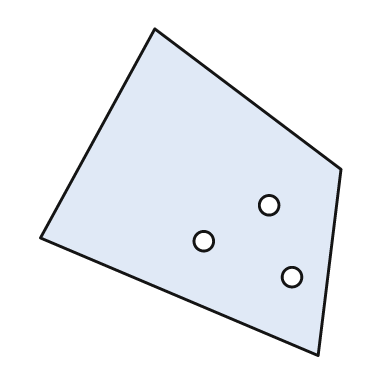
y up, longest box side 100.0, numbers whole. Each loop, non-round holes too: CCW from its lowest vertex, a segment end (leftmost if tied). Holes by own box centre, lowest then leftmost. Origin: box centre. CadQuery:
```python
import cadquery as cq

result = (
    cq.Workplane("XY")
    .moveTo(39.0, -50.0)
    .lineTo(46.0, 7.0)
    .lineTo(-11.0, 50.0)
    .lineTo(-46.0, -14.0)
    .close()
    .moveTo(31.0, -26.0)
    .circle(3.0)
    .moveTo(4.0, -15.0)
    .circle(3.0)
    .moveTo(24.0, -4.0)
    .circle(3.0)
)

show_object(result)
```